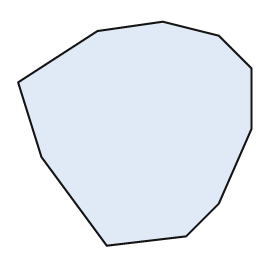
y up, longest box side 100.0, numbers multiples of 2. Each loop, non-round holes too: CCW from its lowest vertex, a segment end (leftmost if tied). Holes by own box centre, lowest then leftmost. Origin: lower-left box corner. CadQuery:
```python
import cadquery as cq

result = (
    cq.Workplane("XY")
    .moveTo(38.0, 0.0)
    .lineTo(72.0, 4.0)
    .lineTo(86.0, 18.0)
    .lineTo(100.0, 50.0)
    .lineTo(100.0, 76.0)
    .lineTo(86.0, 90.0)
    .lineTo(62.0, 96.0)
    .lineTo(34.0, 92.0)
    .lineTo(0.0, 70.0)
    .lineTo(10.0, 38.0)
    .close()
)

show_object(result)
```